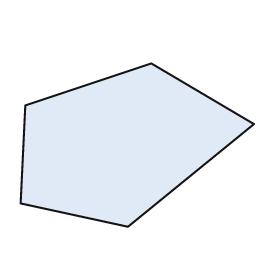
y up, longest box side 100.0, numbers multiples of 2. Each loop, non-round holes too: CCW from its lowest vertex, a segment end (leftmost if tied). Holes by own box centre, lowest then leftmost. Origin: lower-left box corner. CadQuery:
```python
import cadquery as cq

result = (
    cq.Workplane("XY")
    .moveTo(46.0, 0.0)
    .lineTo(100.0, 44.0)
    .lineTo(56.0, 70.0)
    .lineTo(2.0, 52.0)
    .lineTo(0.0, 10.0)
    .close()
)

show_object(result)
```